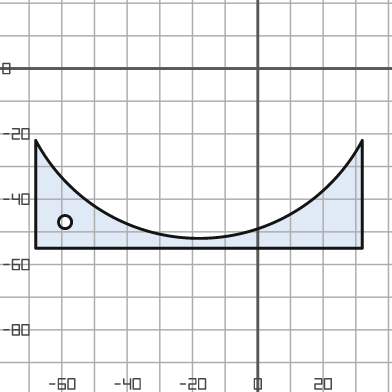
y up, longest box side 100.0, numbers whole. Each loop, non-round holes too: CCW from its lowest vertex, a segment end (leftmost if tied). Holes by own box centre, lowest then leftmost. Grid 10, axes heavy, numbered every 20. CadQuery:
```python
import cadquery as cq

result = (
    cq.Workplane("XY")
    .moveTo(-68.0, -55.0)
    .lineTo(32.0, -55.0)
    .lineTo(32.0, -22.0)
    .threePointArc((-18.0, -52.0), (-68.0, -22.0))
    .close()
    .moveTo(-59.0, -47.0)
    .circle(2.0)
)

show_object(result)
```